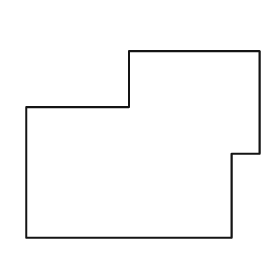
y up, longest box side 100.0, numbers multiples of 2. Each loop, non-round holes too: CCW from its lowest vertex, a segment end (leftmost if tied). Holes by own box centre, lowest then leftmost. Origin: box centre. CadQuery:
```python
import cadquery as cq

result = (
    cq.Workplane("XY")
    .moveTo(-50.0, -40.0)
    .lineTo(38.0, -40.0)
    .lineTo(38.0, -4.0)
    .lineTo(50.0, -4.0)
    .lineTo(50.0, 40.0)
    .lineTo(-6.0, 40.0)
    .lineTo(-6.0, 16.0)
    .lineTo(-50.0, 16.0)
    .close()
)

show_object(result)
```